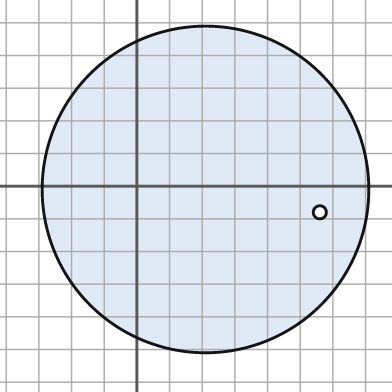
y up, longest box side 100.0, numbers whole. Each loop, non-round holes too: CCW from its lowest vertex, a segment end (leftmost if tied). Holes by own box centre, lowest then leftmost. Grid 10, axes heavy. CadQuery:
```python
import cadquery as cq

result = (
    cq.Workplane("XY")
    .moveTo(21.0, -1.0)
    .circle(50.0)
    .moveTo(56.0, -8.0)
    .circle(2.0)
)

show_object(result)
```